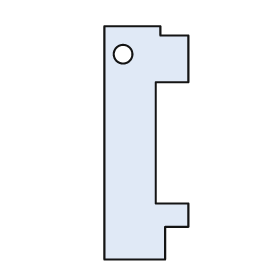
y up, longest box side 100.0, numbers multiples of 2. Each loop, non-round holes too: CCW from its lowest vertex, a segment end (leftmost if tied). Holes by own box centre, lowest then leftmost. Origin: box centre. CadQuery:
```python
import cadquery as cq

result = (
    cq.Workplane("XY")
    .moveTo(-18.0, -50.0)
    .lineTo(8.0, -50.0)
    .lineTo(8.0, -36.0)
    .lineTo(18.0, -36.0)
    .lineTo(18.0, -26.0)
    .lineTo(4.0, -26.0)
    .lineTo(4.0, 26.0)
    .lineTo(18.0, 26.0)
    .lineTo(18.0, 46.0)
    .lineTo(6.0, 46.0)
    .lineTo(6.0, 50.0)
    .lineTo(-18.0, 50.0)
    .close()
    .moveTo(-10.0, 38.0)
    .circle(4.0)
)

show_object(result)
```